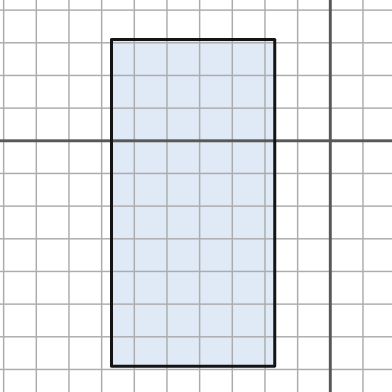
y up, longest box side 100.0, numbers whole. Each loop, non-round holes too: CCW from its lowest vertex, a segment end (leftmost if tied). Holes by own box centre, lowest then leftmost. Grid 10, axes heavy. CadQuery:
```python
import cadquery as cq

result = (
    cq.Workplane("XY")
    .moveTo(-67.0, -69.0)
    .lineTo(-17.0, -69.0)
    .lineTo(-17.0, 31.0)
    .lineTo(-67.0, 31.0)
    .close()
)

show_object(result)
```